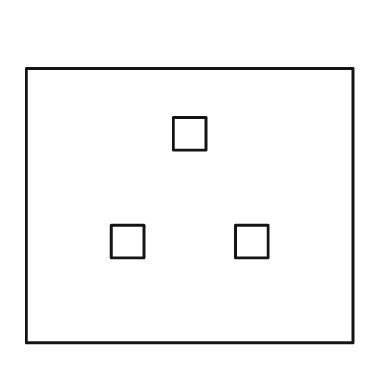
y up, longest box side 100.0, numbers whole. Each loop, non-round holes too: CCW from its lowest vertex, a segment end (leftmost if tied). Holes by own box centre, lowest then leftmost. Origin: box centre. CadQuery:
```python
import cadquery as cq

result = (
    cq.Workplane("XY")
    .moveTo(-50.0, -42.0)
    .lineTo(50.0, -42.0)
    .lineTo(50.0, 42.0)
    .lineTo(-50.0, 42.0)
    .close()
    .moveTo(-24.0, -16.0)
    .lineTo(-14.0, -16.0)
    .lineTo(-14.0, -6.0)
    .lineTo(-24.0, -6.0)
    .close()
    .moveTo(14.0, -16.0)
    .lineTo(24.0, -16.0)
    .lineTo(24.0, -6.0)
    .lineTo(14.0, -6.0)
    .close()
    .moveTo(-5.0, 17.0)
    .lineTo(5.0, 17.0)
    .lineTo(5.0, 27.0)
    .lineTo(-5.0, 27.0)
    .close()
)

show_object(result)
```